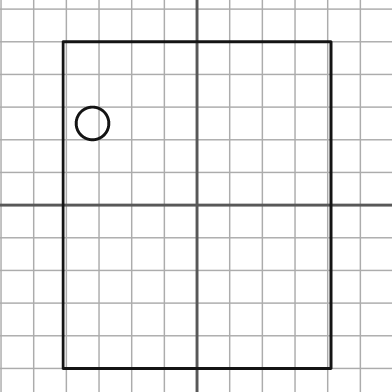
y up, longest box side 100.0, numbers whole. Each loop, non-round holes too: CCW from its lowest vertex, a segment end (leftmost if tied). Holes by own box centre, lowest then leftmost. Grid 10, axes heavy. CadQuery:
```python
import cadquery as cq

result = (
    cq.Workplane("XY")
    .moveTo(-41.0, -50.0)
    .lineTo(41.0, -50.0)
    .lineTo(41.0, 50.0)
    .lineTo(-41.0, 50.0)
    .close()
    .moveTo(-32.0, 25.0)
    .circle(5.0)
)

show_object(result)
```